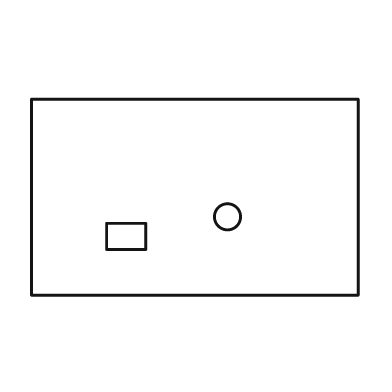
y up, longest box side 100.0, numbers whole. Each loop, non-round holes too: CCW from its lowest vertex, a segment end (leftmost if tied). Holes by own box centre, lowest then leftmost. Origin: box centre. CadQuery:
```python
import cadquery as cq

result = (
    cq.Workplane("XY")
    .moveTo(-50.0, -30.0)
    .lineTo(50.0, -30.0)
    .lineTo(50.0, 30.0)
    .lineTo(-50.0, 30.0)
    .close()
    .moveTo(-27.0, -16.0)
    .lineTo(-15.0, -16.0)
    .lineTo(-15.0, -8.0)
    .lineTo(-27.0, -8.0)
    .close()
    .moveTo(10.0, -6.0)
    .circle(4.0)
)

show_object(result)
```